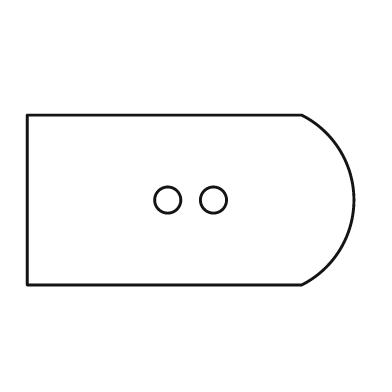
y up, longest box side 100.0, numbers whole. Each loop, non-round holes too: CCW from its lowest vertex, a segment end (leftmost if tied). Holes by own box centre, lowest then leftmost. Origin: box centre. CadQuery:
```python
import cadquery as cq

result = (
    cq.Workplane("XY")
    .moveTo(-50.0, -26.0)
    .lineTo(34.0, -26.0)
    .threePointArc((50.0, 0.0), (34.0, 26.0))
    .lineTo(-50.0, 26.0)
    .close()
    .moveTo(-7.0, 0.0)
    .circle(4.0)
    .moveTo(7.0, 0.0)
    .circle(4.0)
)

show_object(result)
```